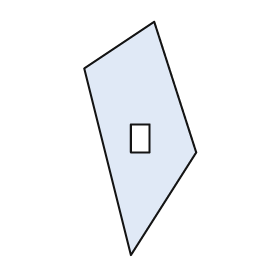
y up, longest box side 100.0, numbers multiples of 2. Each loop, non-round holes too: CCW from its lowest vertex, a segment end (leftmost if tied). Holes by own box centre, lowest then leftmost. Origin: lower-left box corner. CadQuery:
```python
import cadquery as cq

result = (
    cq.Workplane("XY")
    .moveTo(20.0, 0.0)
    .lineTo(48.0, 44.0)
    .lineTo(30.0, 100.0)
    .lineTo(0.0, 80.0)
    .close()
    .moveTo(20.0, 44.0)
    .lineTo(28.0, 44.0)
    .lineTo(28.0, 56.0)
    .lineTo(20.0, 56.0)
    .close()
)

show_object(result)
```